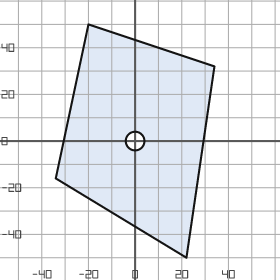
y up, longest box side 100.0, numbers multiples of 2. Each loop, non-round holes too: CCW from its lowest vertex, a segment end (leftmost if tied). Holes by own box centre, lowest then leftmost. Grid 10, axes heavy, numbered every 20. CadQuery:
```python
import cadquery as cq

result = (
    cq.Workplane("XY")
    .moveTo(22.0, -50.0)
    .lineTo(34.0, 32.0)
    .lineTo(-20.0, 50.0)
    .lineTo(-34.0, -16.0)
    .close()
    .moveTo(0.0, 0.0)
    .circle(4.0)
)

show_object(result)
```